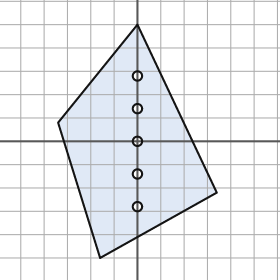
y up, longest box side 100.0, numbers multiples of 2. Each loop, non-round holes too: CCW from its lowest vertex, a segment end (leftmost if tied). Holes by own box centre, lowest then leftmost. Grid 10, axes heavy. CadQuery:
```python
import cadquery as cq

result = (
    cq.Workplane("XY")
    .moveTo(-16.0, -50.0)
    .lineTo(34.0, -22.0)
    .lineTo(0.0, 50.0)
    .lineTo(-34.0, 8.0)
    .close()
    .moveTo(0.0, -28.0)
    .circle(2.0)
    .moveTo(0.0, -14.0)
    .circle(2.0)
    .moveTo(0.0, 0.0)
    .circle(2.0)
    .moveTo(0.0, 14.0)
    .circle(2.0)
    .moveTo(0.0, 28.0)
    .circle(2.0)
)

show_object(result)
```